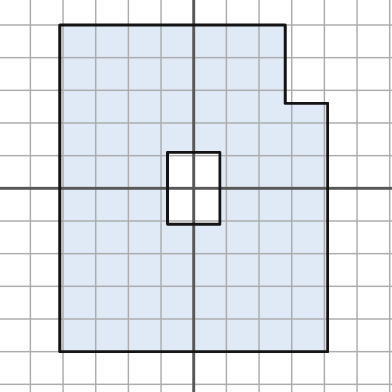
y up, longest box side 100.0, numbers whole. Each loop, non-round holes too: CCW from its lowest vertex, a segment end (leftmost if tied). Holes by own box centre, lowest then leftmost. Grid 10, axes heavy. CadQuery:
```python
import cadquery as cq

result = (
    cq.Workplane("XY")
    .moveTo(-41.0, -50.0)
    .lineTo(41.0, -50.0)
    .lineTo(41.0, 26.0)
    .lineTo(28.0, 26.0)
    .lineTo(28.0, 50.0)
    .lineTo(-41.0, 50.0)
    .close()
    .moveTo(-8.0, -11.0)
    .lineTo(8.0, -11.0)
    .lineTo(8.0, 11.0)
    .lineTo(-8.0, 11.0)
    .close()
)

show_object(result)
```